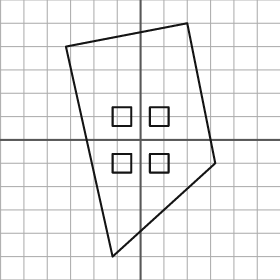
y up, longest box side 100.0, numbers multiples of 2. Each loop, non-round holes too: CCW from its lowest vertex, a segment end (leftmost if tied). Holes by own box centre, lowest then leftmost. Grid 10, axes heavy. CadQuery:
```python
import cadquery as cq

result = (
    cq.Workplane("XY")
    .moveTo(-12.0, -50.0)
    .lineTo(32.0, -10.0)
    .lineTo(20.0, 50.0)
    .lineTo(-32.0, 40.0)
    .close()
    .moveTo(-12.0, -14.0)
    .lineTo(-4.0, -14.0)
    .lineTo(-4.0, -6.0)
    .lineTo(-12.0, -6.0)
    .close()
    .moveTo(4.0, -14.0)
    .lineTo(12.0, -14.0)
    .lineTo(12.0, -6.0)
    .lineTo(4.0, -6.0)
    .close()
    .moveTo(-12.0, 6.0)
    .lineTo(-4.0, 6.0)
    .lineTo(-4.0, 14.0)
    .lineTo(-12.0, 14.0)
    .close()
    .moveTo(4.0, 6.0)
    .lineTo(12.0, 6.0)
    .lineTo(12.0, 14.0)
    .lineTo(4.0, 14.0)
    .close()
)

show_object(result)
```